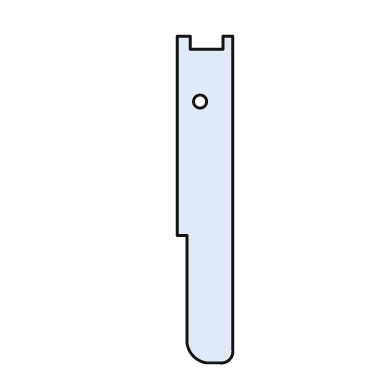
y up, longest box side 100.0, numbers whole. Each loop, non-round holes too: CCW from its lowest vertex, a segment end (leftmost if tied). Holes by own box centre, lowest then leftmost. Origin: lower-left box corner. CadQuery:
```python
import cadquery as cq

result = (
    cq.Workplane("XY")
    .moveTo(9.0, 0.0)
    .lineTo(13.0, 0.0)
    .threePointArc((16.0, 1.0), (17.0, 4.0))
    .lineTo(17.0, 100.0)
    .lineTo(14.0, 100.0)
    .lineTo(14.0, 96.0)
    .lineTo(4.0, 96.0)
    .lineTo(4.0, 100.0)
    .lineTo(0.0, 100.0)
    .lineTo(0.0, 39.0)
    .lineTo(3.0, 39.0)
    .lineTo(3.0, 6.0)
    .threePointArc((5.0, 2.0), (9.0, 0.0))
    .close()
    .moveTo(7.0, 80.0)
    .circle(2.0)
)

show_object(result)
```